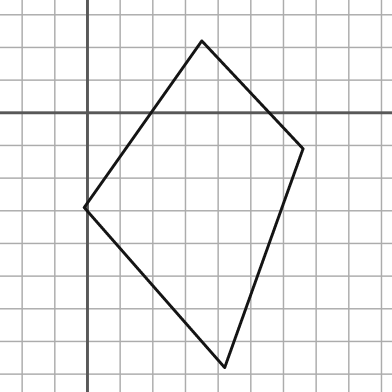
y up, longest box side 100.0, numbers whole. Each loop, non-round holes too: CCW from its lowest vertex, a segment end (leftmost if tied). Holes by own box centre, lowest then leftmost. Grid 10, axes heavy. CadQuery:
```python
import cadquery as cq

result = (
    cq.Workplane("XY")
    .moveTo(42.0, -78.0)
    .lineTo(66.0, -11.0)
    .lineTo(35.0, 22.0)
    .lineTo(-1.0, -29.0)
    .close()
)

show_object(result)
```